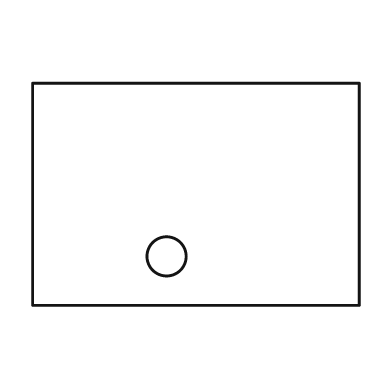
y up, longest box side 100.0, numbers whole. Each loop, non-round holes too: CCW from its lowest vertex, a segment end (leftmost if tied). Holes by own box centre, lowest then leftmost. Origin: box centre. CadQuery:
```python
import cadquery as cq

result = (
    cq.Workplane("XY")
    .moveTo(-50.0, -34.0)
    .lineTo(50.0, -34.0)
    .lineTo(50.0, 34.0)
    .lineTo(-50.0, 34.0)
    .close()
    .moveTo(-9.0, -19.0)
    .circle(6.0)
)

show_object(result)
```